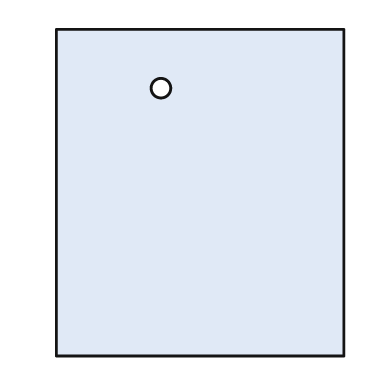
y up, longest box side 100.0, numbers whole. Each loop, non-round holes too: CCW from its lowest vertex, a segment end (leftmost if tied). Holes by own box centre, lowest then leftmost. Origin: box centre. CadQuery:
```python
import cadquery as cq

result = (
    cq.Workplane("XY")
    .moveTo(-44.0, -50.0)
    .lineTo(44.0, -50.0)
    .lineTo(44.0, 50.0)
    .lineTo(-44.0, 50.0)
    .close()
    .moveTo(-12.0, 32.0)
    .circle(3.0)
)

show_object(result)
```